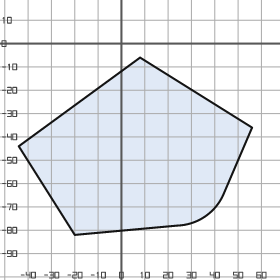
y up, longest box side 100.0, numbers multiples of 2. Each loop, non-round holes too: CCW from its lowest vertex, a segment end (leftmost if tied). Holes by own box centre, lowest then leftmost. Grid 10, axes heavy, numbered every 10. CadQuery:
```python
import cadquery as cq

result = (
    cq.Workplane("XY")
    .moveTo(-20.0, -82.0)
    .lineTo(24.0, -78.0)
    .threePointArc((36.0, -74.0), (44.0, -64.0))
    .lineTo(56.0, -36.0)
    .lineTo(8.0, -6.0)
    .lineTo(-44.0, -44.0)
    .close()
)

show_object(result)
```